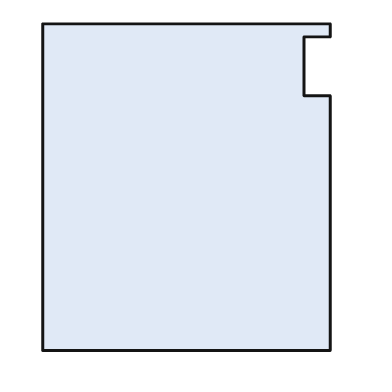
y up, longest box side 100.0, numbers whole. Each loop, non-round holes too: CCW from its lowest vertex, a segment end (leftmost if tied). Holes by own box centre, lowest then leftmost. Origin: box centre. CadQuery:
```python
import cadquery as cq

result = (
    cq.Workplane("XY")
    .moveTo(-44.0, -50.0)
    .lineTo(44.0, -50.0)
    .lineTo(44.0, 28.0)
    .lineTo(36.0, 28.0)
    .lineTo(36.0, 46.0)
    .lineTo(44.0, 46.0)
    .lineTo(44.0, 50.0)
    .lineTo(-44.0, 50.0)
    .close()
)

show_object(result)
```